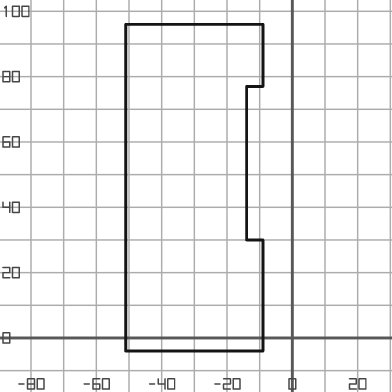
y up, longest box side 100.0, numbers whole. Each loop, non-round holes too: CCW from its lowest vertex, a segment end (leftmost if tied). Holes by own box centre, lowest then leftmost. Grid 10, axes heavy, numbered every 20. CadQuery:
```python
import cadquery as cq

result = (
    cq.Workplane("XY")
    .moveTo(-51.0, -4.0)
    .lineTo(-9.0, -4.0)
    .lineTo(-9.0, 30.0)
    .lineTo(-14.0, 30.0)
    .lineTo(-14.0, 77.0)
    .lineTo(-9.0, 77.0)
    .lineTo(-9.0, 96.0)
    .lineTo(-51.0, 96.0)
    .close()
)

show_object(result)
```